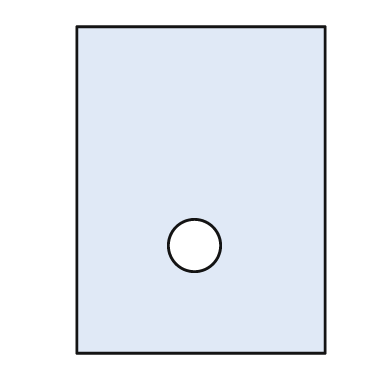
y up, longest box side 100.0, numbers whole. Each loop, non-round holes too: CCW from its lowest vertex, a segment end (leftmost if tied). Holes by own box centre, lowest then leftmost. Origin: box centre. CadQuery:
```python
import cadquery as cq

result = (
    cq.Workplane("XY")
    .moveTo(-38.0, -50.0)
    .lineTo(38.0, -50.0)
    .lineTo(38.0, 50.0)
    .lineTo(-38.0, 50.0)
    .close()
    .moveTo(-2.0, -17.0)
    .circle(8.0)
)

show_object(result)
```